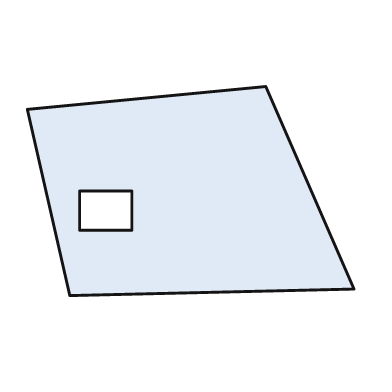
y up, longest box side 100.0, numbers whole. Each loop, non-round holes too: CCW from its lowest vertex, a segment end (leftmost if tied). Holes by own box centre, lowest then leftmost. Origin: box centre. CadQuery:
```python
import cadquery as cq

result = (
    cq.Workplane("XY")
    .moveTo(-37.0, -32.0)
    .lineTo(50.0, -30.0)
    .lineTo(23.0, 32.0)
    .lineTo(-50.0, 25.0)
    .close()
    .moveTo(-34.0, -12.0)
    .lineTo(-18.0, -12.0)
    .lineTo(-18.0, 0.0)
    .lineTo(-34.0, 0.0)
    .close()
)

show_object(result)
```